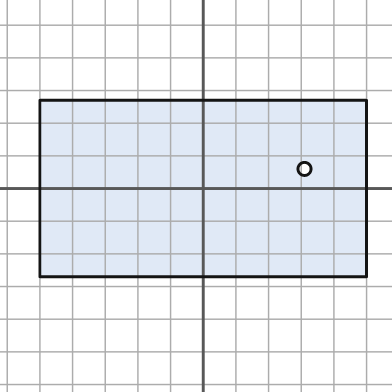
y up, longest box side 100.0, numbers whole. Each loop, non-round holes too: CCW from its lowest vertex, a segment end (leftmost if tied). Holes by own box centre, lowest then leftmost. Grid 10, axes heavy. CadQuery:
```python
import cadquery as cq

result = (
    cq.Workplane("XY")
    .moveTo(-50.0, -27.0)
    .lineTo(50.0, -27.0)
    .lineTo(50.0, 27.0)
    .lineTo(-50.0, 27.0)
    .close()
    .moveTo(31.0, 6.0)
    .circle(2.0)
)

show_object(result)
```